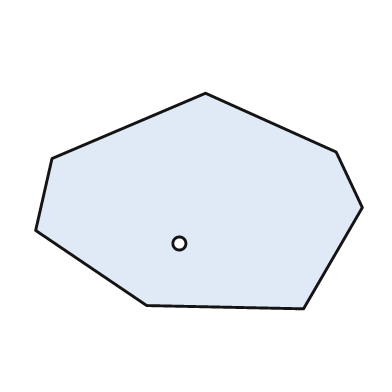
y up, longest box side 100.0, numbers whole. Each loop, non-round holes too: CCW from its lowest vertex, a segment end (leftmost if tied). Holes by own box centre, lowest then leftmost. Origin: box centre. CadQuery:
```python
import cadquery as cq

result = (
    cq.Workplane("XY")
    .moveTo(32.0, -33.0)
    .lineTo(50.0, -2.0)
    .lineTo(42.0, 15.0)
    .lineTo(2.0, 33.0)
    .lineTo(-45.0, 13.0)
    .lineTo(-50.0, -9.0)
    .lineTo(-16.0, -32.0)
    .close()
    .moveTo(-6.0, -13.0)
    .circle(2.0)
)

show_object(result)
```